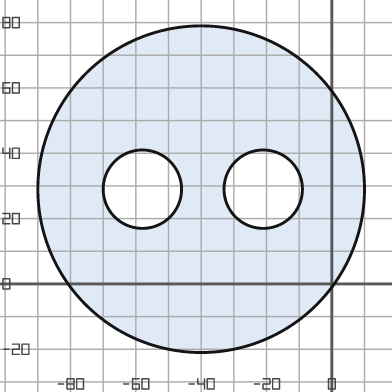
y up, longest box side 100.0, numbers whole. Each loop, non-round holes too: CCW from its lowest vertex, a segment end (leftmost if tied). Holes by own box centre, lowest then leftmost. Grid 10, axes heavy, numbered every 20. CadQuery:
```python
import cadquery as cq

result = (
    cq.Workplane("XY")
    .moveTo(-40.0, 29.0)
    .circle(50.0)
    .moveTo(-58.0, 29.0)
    .circle(12.0)
    .moveTo(-21.0, 29.0)
    .circle(12.0)
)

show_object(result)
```